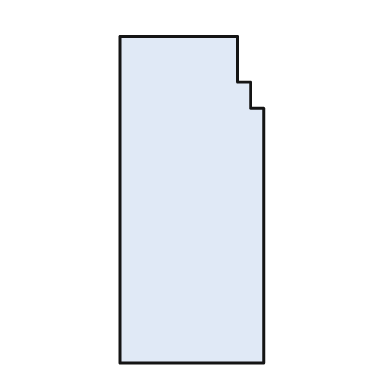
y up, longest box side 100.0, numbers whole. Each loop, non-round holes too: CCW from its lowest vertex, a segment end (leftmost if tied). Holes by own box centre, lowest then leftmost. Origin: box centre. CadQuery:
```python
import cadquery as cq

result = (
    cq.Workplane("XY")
    .moveTo(-22.0, -50.0)
    .lineTo(22.0, -50.0)
    .lineTo(22.0, 28.0)
    .lineTo(18.0, 28.0)
    .lineTo(18.0, 36.0)
    .lineTo(14.0, 36.0)
    .lineTo(14.0, 50.0)
    .lineTo(-22.0, 50.0)
    .close()
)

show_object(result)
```